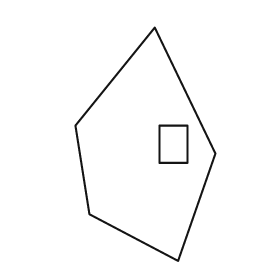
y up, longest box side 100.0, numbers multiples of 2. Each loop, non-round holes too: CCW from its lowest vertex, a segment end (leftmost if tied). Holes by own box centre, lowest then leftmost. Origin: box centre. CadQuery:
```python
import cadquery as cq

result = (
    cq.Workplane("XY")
    .moveTo(14.0, -50.0)
    .lineTo(30.0, -4.0)
    .lineTo(4.0, 50.0)
    .lineTo(-30.0, 8.0)
    .lineTo(-24.0, -30.0)
    .close()
    .moveTo(6.0, -8.0)
    .lineTo(18.0, -8.0)
    .lineTo(18.0, 8.0)
    .lineTo(6.0, 8.0)
    .close()
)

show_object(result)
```